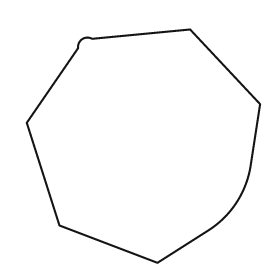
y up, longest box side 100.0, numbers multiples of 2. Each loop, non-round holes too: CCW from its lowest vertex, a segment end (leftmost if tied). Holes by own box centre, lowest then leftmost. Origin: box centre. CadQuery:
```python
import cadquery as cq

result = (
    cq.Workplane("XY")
    .moveTo(6.0, -50.0)
    .lineTo(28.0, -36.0)
    .threePointArc((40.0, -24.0), (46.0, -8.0))
    .lineTo(50.0, 18.0)
    .lineTo(20.0, 50.0)
    .lineTo(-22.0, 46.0)
    .threePointArc((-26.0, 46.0), (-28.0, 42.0))
    .lineTo(-50.0, 10.0)
    .lineTo(-36.0, -34.0)
    .close()
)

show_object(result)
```